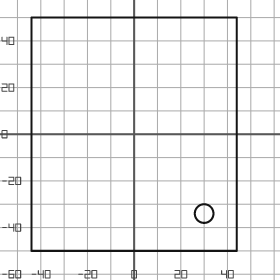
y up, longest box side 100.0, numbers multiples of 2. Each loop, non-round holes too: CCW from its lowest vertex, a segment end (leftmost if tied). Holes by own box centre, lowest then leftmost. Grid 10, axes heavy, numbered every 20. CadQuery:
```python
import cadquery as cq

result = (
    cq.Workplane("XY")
    .moveTo(-44.0, -50.0)
    .lineTo(44.0, -50.0)
    .lineTo(44.0, 50.0)
    .lineTo(-44.0, 50.0)
    .close()
    .moveTo(30.0, -34.0)
    .circle(4.0)
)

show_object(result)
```